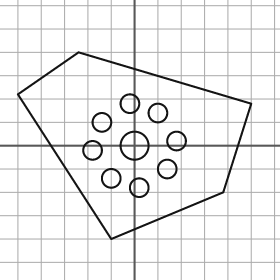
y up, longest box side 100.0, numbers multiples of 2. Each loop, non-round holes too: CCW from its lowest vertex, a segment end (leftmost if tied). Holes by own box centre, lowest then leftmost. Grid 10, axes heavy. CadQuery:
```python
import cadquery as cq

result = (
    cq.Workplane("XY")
    .moveTo(-10.0, -40.0)
    .lineTo(38.0, -20.0)
    .lineTo(50.0, 18.0)
    .lineTo(-24.0, 40.0)
    .lineTo(-50.0, 22.0)
    .close()
    .moveTo(2.0, -18.0)
    .circle(4.0)
    .moveTo(-10.0, -14.0)
    .circle(4.0)
    .moveTo(14.0, -10.0)
    .circle(4.0)
    .moveTo(-18.0, -2.0)
    .circle(4.0)
    .moveTo(0.0, 0.0)
    .circle(6.0)
    .moveTo(18.0, 2.0)
    .circle(4.0)
    .moveTo(-14.0, 10.0)
    .circle(4.0)
    .moveTo(10.0, 14.0)
    .circle(4.0)
    .moveTo(-2.0, 18.0)
    .circle(4.0)
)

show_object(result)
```